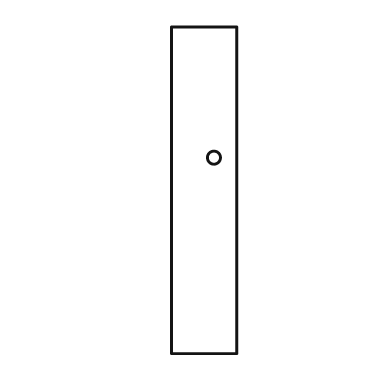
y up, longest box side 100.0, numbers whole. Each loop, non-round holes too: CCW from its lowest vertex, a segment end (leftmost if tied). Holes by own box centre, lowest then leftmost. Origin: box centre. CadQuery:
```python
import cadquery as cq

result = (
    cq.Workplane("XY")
    .moveTo(-10.0, -50.0)
    .lineTo(10.0, -50.0)
    .lineTo(10.0, 50.0)
    .lineTo(-10.0, 50.0)
    .close()
    .moveTo(3.0, 10.0)
    .circle(2.0)
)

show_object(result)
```